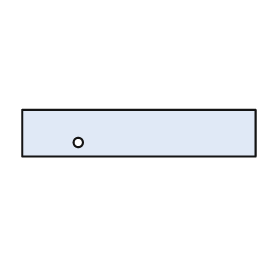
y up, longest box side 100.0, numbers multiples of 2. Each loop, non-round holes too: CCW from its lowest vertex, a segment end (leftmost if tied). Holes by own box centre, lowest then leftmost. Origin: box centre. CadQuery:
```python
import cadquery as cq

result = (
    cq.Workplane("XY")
    .moveTo(-50.0, -10.0)
    .lineTo(50.0, -10.0)
    .lineTo(50.0, 10.0)
    .lineTo(-50.0, 10.0)
    .close()
    .moveTo(-26.0, -4.0)
    .circle(2.0)
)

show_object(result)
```